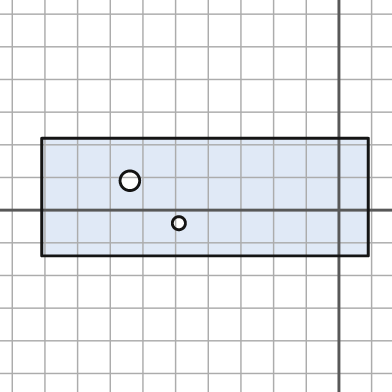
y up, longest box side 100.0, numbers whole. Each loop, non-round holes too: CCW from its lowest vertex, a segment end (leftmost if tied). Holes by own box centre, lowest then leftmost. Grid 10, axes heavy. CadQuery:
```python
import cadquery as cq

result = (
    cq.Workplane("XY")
    .moveTo(-91.0, -14.0)
    .lineTo(9.0, -14.0)
    .lineTo(9.0, 22.0)
    .lineTo(-91.0, 22.0)
    .close()
    .moveTo(-49.0, -4.0)
    .circle(2.0)
    .moveTo(-64.0, 9.0)
    .circle(3.0)
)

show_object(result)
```